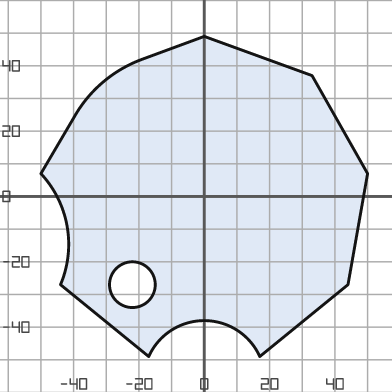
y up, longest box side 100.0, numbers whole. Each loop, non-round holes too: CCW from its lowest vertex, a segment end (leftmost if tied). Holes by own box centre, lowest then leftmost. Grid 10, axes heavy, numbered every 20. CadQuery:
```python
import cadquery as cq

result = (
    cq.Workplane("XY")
    .moveTo(-17.0, -49.0)
    .threePointArc((0.0, -38.0), (17.0, -49.0))
    .lineTo(44.0, -27.0)
    .lineTo(50.0, 7.0)
    .lineTo(33.0, 37.0)
    .lineTo(0.0, 49.0)
    .lineTo(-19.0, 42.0)
    .threePointArc((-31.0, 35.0), (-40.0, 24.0))
    .lineTo(-50.0, 7.0)
    .threePointArc((-42.0, -9.0), (-44.0, -27.0))
    .close()
    .moveTo(-22.0, -27.0)
    .circle(7.0)
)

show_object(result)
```